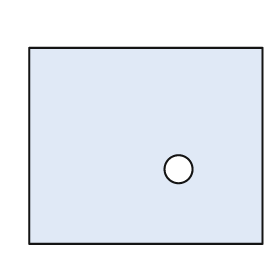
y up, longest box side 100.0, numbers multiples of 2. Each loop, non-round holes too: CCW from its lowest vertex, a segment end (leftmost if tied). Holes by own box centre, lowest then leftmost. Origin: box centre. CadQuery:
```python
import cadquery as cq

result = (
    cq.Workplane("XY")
    .moveTo(-50.0, -42.0)
    .lineTo(50.0, -42.0)
    .lineTo(50.0, 42.0)
    .lineTo(-50.0, 42.0)
    .close()
    .moveTo(14.0, -10.0)
    .circle(6.0)
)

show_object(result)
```